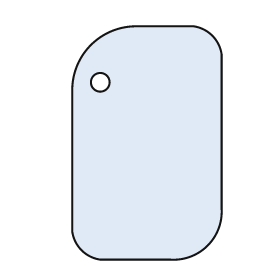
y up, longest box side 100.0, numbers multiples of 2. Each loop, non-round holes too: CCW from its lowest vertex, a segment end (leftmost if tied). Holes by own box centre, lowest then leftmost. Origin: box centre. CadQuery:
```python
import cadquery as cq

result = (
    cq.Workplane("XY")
    .moveTo(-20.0, -50.0)
    .lineTo(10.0, -50.0)
    .threePointArc((26.0, -44.0), (32.0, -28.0))
    .lineTo(32.0, 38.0)
    .threePointArc((28.0, 46.0), (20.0, 50.0))
    .lineTo(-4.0, 50.0)
    .threePointArc((-24.0, 42.0), (-32.0, 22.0))
    .lineTo(-32.0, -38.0)
    .threePointArc((-28.0, -46.0), (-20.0, -50.0))
    .close()
    .moveTo(-20.0, 26.0)
    .circle(4.0)
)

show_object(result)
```